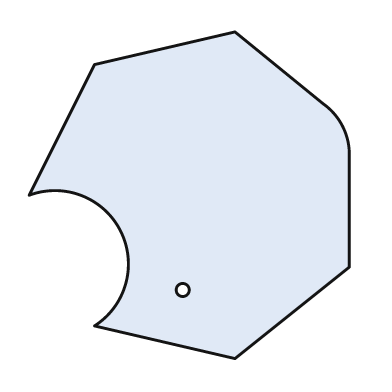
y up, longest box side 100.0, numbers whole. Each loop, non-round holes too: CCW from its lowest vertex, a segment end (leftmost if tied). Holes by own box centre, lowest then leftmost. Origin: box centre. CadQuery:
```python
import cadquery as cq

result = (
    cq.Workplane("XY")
    .moveTo(14.0, -50.0)
    .lineTo(49.0, -22.0)
    .lineTo(49.0, 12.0)
    .threePointArc((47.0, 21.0), (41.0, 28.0))
    .lineTo(14.0, 50.0)
    .lineTo(-29.0, 40.0)
    .lineTo(-49.0, 0.0)
    .threePointArc((-21.0, -11.0), (-29.0, -40.0))
    .close()
    .moveTo(-2.0, -29.0)
    .circle(2.0)
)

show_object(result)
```